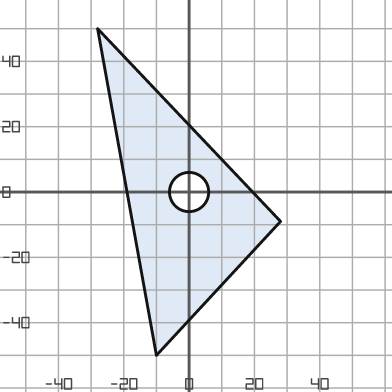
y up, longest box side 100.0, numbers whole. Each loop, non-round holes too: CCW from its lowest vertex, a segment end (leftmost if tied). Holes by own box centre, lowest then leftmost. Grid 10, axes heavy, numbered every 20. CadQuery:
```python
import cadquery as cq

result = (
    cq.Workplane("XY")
    .moveTo(-10.0, -50.0)
    .lineTo(28.0, -9.0)
    .lineTo(-28.0, 50.0)
    .close()
    .moveTo(0.0, 0.0)
    .circle(6.0)
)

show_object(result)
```